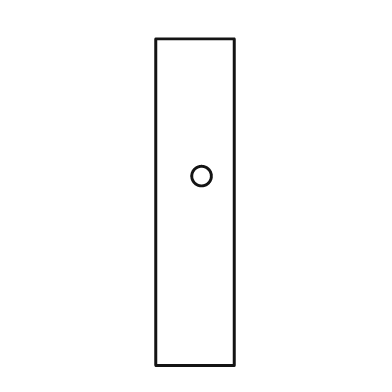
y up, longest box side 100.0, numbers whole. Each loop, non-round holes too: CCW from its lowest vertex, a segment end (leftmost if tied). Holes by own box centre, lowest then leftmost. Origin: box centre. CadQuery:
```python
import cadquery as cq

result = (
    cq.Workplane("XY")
    .moveTo(-12.0, -50.0)
    .lineTo(12.0, -50.0)
    .lineTo(12.0, 50.0)
    .lineTo(-12.0, 50.0)
    .close()
    .moveTo(2.0, 8.0)
    .circle(3.0)
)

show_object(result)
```